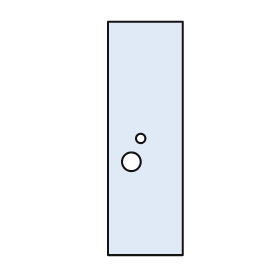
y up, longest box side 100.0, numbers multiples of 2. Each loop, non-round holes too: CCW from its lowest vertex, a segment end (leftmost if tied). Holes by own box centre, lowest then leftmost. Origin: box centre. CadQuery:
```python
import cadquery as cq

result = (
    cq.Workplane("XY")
    .moveTo(-16.0, -50.0)
    .lineTo(16.0, -50.0)
    .lineTo(16.0, 50.0)
    .lineTo(-16.0, 50.0)
    .close()
    .moveTo(-6.0, -10.0)
    .circle(4.0)
    .moveTo(-2.0, 0.0)
    .circle(2.0)
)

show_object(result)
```